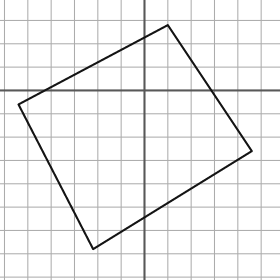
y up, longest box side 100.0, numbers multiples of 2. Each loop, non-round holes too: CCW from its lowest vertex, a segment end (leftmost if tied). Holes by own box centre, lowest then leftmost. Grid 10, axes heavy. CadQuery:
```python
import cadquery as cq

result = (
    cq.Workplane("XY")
    .moveTo(-22.0, -68.0)
    .lineTo(46.0, -26.0)
    .lineTo(10.0, 28.0)
    .lineTo(-54.0, -6.0)
    .close()
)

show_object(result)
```